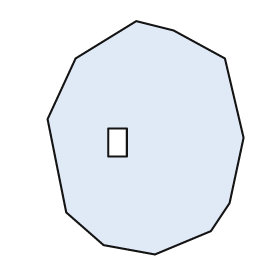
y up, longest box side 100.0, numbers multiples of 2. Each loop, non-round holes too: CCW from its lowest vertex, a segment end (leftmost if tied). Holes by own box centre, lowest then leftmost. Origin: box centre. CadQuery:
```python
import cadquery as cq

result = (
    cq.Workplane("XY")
    .moveTo(4.0, -50.0)
    .lineTo(28.0, -40.0)
    .lineTo(36.0, -28.0)
    .lineTo(42.0, 0.0)
    .lineTo(34.0, 34.0)
    .lineTo(12.0, 46.0)
    .lineTo(-4.0, 50.0)
    .lineTo(-30.0, 34.0)
    .lineTo(-42.0, 8.0)
    .lineTo(-34.0, -32.0)
    .lineTo(-18.0, -46.0)
    .close()
    .moveTo(-16.0, -8.0)
    .lineTo(-8.0, -8.0)
    .lineTo(-8.0, 4.0)
    .lineTo(-16.0, 4.0)
    .close()
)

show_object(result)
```